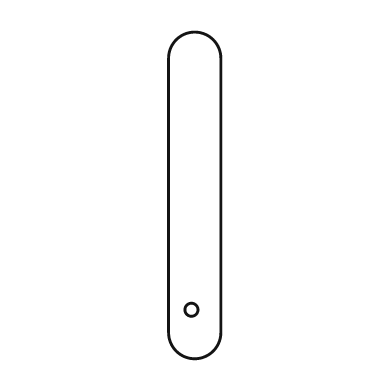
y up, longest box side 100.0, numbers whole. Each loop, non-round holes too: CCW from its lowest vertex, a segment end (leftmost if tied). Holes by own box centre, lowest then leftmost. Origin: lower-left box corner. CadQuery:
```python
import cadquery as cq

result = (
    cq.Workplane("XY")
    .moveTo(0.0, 8.0)
    .threePointArc((8.0, 0.0), (16.0, 8.0))
    .lineTo(16.0, 92.0)
    .threePointArc((8.0, 100.0), (0.0, 92.0))
    .close()
    .moveTo(7.0, 15.0)
    .circle(2.0)
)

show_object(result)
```